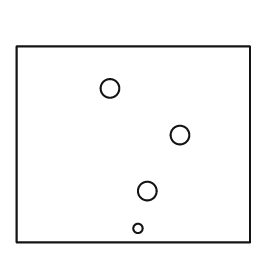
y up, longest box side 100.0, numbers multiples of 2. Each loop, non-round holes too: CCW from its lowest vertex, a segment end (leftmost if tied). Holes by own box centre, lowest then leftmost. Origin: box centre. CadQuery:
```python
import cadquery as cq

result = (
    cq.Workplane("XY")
    .moveTo(-50.0, -42.0)
    .lineTo(50.0, -42.0)
    .lineTo(50.0, 42.0)
    .lineTo(-50.0, 42.0)
    .close()
    .moveTo(2.0, -36.0)
    .circle(2.0)
    .moveTo(6.0, -20.0)
    .circle(4.0)
    .moveTo(20.0, 4.0)
    .circle(4.0)
    .moveTo(-10.0, 24.0)
    .circle(4.0)
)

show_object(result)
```